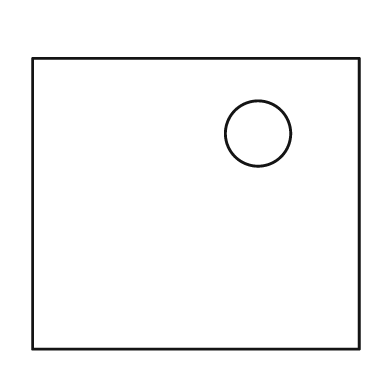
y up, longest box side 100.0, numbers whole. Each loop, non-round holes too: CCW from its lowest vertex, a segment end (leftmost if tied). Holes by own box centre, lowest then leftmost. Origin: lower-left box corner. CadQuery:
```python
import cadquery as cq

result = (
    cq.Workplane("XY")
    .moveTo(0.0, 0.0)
    .lineTo(100.0, 0.0)
    .lineTo(100.0, 89.0)
    .lineTo(0.0, 89.0)
    .close()
    .moveTo(69.0, 66.0)
    .circle(10.0)
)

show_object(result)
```